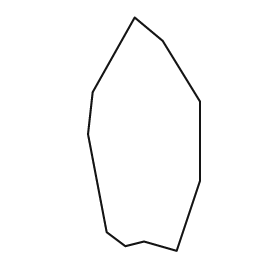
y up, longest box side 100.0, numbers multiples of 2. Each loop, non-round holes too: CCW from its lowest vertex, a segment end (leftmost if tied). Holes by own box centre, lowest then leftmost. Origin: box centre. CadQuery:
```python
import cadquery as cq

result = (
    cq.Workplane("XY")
    .moveTo(14.0, -50.0)
    .lineTo(24.0, -20.0)
    .lineTo(24.0, 14.0)
    .lineTo(8.0, 40.0)
    .lineTo(-4.0, 50.0)
    .lineTo(-22.0, 18.0)
    .lineTo(-24.0, 0.0)
    .lineTo(-16.0, -42.0)
    .lineTo(-8.0, -48.0)
    .lineTo(0.0, -46.0)
    .close()
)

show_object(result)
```